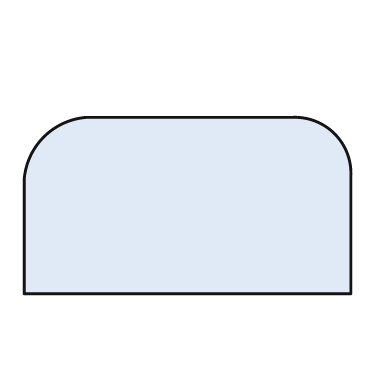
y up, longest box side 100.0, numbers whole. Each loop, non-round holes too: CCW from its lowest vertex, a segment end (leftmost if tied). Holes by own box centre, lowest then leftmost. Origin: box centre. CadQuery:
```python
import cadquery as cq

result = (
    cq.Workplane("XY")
    .moveTo(-50.0, -27.0)
    .lineTo(50.0, -27.0)
    .lineTo(50.0, 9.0)
    .threePointArc((45.0, 22.0), (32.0, 27.0))
    .lineTo(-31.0, 27.0)
    .threePointArc((-44.0, 21.0), (-50.0, 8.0))
    .close()
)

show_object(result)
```